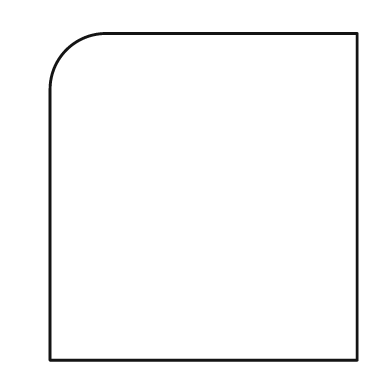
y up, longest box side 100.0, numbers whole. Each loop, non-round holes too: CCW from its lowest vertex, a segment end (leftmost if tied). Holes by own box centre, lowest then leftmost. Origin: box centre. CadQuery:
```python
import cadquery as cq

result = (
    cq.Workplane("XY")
    .moveTo(-47.0, -50.0)
    .lineTo(47.0, -50.0)
    .lineTo(47.0, 50.0)
    .lineTo(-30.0, 50.0)
    .threePointArc((-42.0, 45.0), (-47.0, 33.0))
    .close()
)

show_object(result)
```